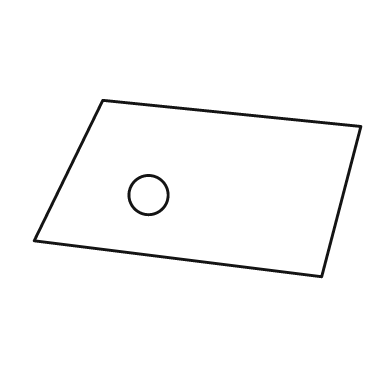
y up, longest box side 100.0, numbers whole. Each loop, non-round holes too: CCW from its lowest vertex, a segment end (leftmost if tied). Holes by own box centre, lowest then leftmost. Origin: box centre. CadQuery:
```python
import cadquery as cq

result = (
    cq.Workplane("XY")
    .moveTo(38.0, -27.0)
    .lineTo(50.0, 19.0)
    .lineTo(-29.0, 27.0)
    .lineTo(-50.0, -16.0)
    .close()
    .moveTo(-15.0, -2.0)
    .circle(6.0)
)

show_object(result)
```